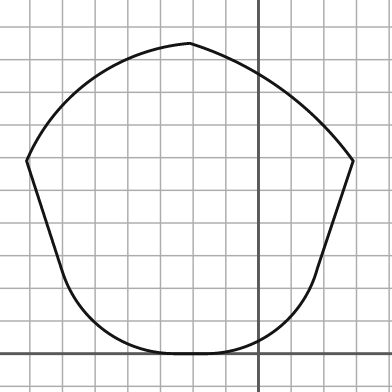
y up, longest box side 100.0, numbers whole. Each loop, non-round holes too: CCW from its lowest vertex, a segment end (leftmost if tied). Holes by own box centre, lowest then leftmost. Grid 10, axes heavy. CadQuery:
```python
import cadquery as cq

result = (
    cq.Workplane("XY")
    .moveTo(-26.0, 0.0)
    .lineTo(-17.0, 0.0)
    .threePointArc((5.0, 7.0), (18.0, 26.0))
    .lineTo(29.0, 59.0)
    .threePointArc((7.0, 81.0), (-21.0, 95.0))
    .threePointArc((-51.0, 84.0), (-71.0, 59.0))
    .lineTo(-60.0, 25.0)
    .threePointArc((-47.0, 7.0), (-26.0, 0.0))
    .close()
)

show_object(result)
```